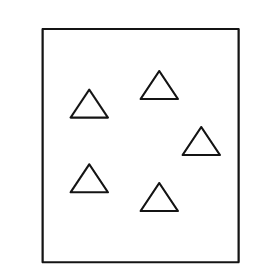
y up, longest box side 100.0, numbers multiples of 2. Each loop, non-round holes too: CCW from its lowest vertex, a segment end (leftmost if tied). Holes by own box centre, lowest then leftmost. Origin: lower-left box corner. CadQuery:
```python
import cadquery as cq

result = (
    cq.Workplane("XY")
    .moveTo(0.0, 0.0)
    .lineTo(84.0, 0.0)
    .lineTo(84.0, 100.0)
    .lineTo(0.0, 100.0)
    .close()
    .moveTo(42.0, 22.0)
    .lineTo(58.0, 22.0)
    .lineTo(50.0, 34.0)
    .close()
    .moveTo(12.0, 30.0)
    .lineTo(28.0, 30.0)
    .lineTo(20.0, 42.0)
    .close()
    .moveTo(60.0, 46.0)
    .lineTo(76.0, 46.0)
    .lineTo(68.0, 58.0)
    .close()
    .moveTo(12.0, 62.0)
    .lineTo(28.0, 62.0)
    .lineTo(20.0, 74.0)
    .close()
    .moveTo(42.0, 70.0)
    .lineTo(58.0, 70.0)
    .lineTo(50.0, 82.0)
    .close()
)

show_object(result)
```